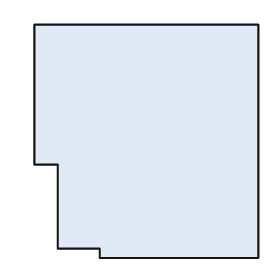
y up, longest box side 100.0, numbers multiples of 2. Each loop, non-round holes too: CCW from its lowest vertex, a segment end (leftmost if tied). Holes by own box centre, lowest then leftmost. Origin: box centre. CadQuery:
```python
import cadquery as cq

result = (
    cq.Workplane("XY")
    .moveTo(-20.0, -50.0)
    .lineTo(48.0, -50.0)
    .lineTo(48.0, 50.0)
    .lineTo(-48.0, 50.0)
    .lineTo(-48.0, -10.0)
    .lineTo(-38.0, -10.0)
    .lineTo(-38.0, -46.0)
    .lineTo(-20.0, -46.0)
    .close()
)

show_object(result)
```